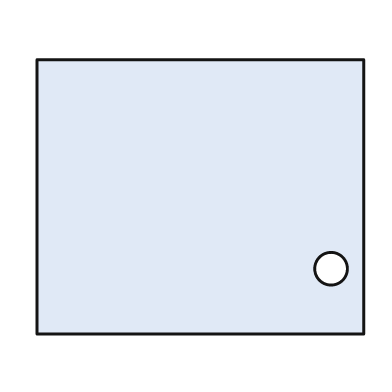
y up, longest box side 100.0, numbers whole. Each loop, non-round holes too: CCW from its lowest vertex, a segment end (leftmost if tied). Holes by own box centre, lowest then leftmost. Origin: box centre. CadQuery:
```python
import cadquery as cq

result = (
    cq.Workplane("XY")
    .moveTo(-50.0, -42.0)
    .lineTo(50.0, -42.0)
    .lineTo(50.0, 42.0)
    .lineTo(-50.0, 42.0)
    .close()
    .moveTo(40.0, -22.0)
    .circle(5.0)
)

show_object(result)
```